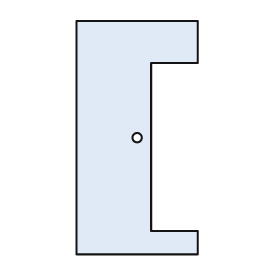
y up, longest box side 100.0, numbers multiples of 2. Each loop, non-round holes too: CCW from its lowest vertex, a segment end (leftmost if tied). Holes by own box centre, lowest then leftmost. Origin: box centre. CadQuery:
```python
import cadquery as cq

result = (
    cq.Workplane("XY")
    .moveTo(-26.0, -50.0)
    .lineTo(26.0, -50.0)
    .lineTo(26.0, -40.0)
    .lineTo(6.0, -40.0)
    .lineTo(6.0, 32.0)
    .lineTo(26.0, 32.0)
    .lineTo(26.0, 50.0)
    .lineTo(-26.0, 50.0)
    .close()
    .moveTo(0.0, 0.0)
    .circle(2.0)
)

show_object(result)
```